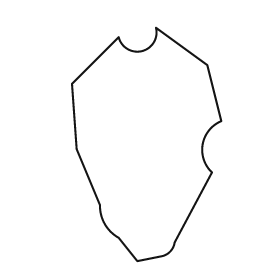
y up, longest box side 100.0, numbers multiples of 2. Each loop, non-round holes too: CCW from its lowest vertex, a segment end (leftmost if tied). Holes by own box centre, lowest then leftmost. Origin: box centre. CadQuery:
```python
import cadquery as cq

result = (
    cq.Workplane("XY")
    .moveTo(-4.0, -50.0)
    .lineTo(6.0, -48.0)
    .threePointArc((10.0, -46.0), (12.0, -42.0))
    .lineTo(28.0, -12.0)
    .threePointArc((24.0, 0.0), (32.0, 10.0))
    .lineTo(26.0, 34.0)
    .lineTo(4.0, 50.0)
    .threePointArc((-2.0, 40.0), (-12.0, 46.0))
    .lineTo(-32.0, 26.0)
    .lineTo(-30.0, -2.0)
    .lineTo(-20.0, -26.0)
    .threePointArc((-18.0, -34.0), (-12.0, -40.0))
    .close()
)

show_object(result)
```